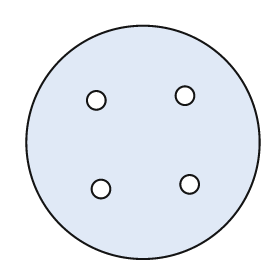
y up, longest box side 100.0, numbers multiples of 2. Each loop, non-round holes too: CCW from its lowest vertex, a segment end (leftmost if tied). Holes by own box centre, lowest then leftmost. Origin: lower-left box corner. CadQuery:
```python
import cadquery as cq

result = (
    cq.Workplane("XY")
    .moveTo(50.0, 50.0)
    .circle(50.0)
    .moveTo(32.0, 30.0)
    .circle(4.0)
    .moveTo(70.0, 32.0)
    .circle(4.0)
    .moveTo(30.0, 68.0)
    .circle(4.0)
    .moveTo(68.0, 70.0)
    .circle(4.0)
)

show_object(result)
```